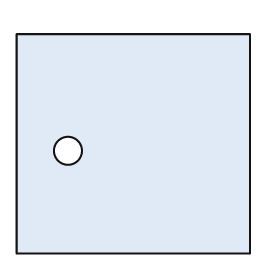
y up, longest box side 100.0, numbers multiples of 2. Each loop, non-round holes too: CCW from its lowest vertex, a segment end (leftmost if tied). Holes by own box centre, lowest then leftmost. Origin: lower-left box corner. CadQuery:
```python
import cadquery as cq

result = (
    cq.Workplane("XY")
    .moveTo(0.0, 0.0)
    .lineTo(100.0, 0.0)
    .lineTo(100.0, 94.0)
    .lineTo(0.0, 94.0)
    .close()
    .moveTo(22.0, 44.0)
    .circle(6.0)
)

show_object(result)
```